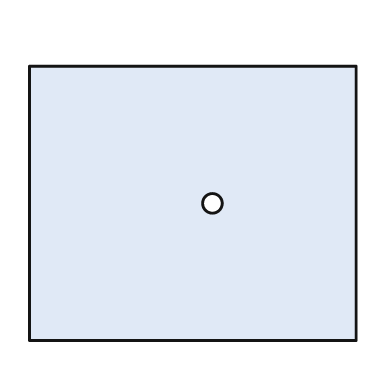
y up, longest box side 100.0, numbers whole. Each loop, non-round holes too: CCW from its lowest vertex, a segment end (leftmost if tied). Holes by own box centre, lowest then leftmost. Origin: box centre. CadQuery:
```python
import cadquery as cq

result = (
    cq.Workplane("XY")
    .moveTo(-50.0, -42.0)
    .lineTo(50.0, -42.0)
    .lineTo(50.0, 42.0)
    .lineTo(-50.0, 42.0)
    .close()
    .moveTo(6.0, 0.0)
    .circle(3.0)
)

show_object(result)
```